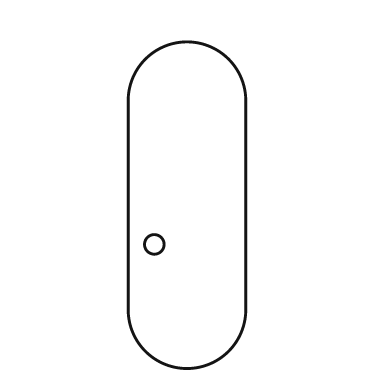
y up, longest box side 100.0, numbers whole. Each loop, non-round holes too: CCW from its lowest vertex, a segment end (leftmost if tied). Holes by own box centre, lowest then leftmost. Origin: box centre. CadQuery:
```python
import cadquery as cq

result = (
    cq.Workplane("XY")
    .moveTo(-18.0, -32.0)
    .threePointArc((0.0, -50.0), (18.0, -32.0))
    .lineTo(18.0, 32.0)
    .threePointArc((0.0, 50.0), (-18.0, 32.0))
    .close()
    .moveTo(-10.0, -12.0)
    .circle(3.0)
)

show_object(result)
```